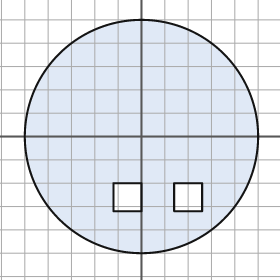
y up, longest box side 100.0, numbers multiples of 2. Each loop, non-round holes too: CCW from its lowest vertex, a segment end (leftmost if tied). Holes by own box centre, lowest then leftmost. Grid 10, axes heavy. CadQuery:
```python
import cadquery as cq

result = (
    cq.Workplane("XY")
    .moveTo(0.0, 0.0)
    .circle(50.0)
    .moveTo(-12.0, -32.0)
    .lineTo(0.0, -32.0)
    .lineTo(0.0, -20.0)
    .lineTo(-12.0, -20.0)
    .close()
    .moveTo(14.0, -32.0)
    .lineTo(26.0, -32.0)
    .lineTo(26.0, -20.0)
    .lineTo(14.0, -20.0)
    .close()
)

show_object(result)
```